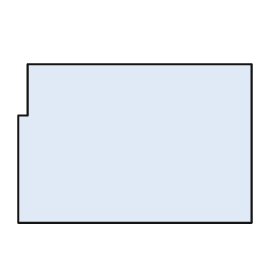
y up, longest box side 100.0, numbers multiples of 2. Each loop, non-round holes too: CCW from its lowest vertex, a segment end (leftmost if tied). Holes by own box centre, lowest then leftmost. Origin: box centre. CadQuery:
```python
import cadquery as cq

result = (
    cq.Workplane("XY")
    .moveTo(-50.0, -34.0)
    .lineTo(50.0, -34.0)
    .lineTo(50.0, 34.0)
    .lineTo(-46.0, 34.0)
    .lineTo(-46.0, 12.0)
    .lineTo(-50.0, 12.0)
    .close()
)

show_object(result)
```